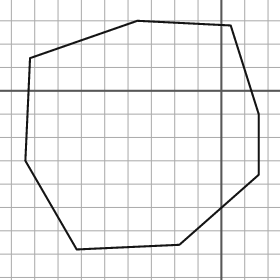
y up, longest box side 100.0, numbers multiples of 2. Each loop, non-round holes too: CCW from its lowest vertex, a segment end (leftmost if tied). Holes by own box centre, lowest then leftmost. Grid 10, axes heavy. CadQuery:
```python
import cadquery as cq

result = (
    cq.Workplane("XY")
    .moveTo(-62.0, -68.0)
    .lineTo(-18.0, -66.0)
    .lineTo(16.0, -36.0)
    .lineTo(16.0, -10.0)
    .lineTo(4.0, 28.0)
    .lineTo(-36.0, 30.0)
    .lineTo(-82.0, 14.0)
    .lineTo(-84.0, -30.0)
    .close()
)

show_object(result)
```